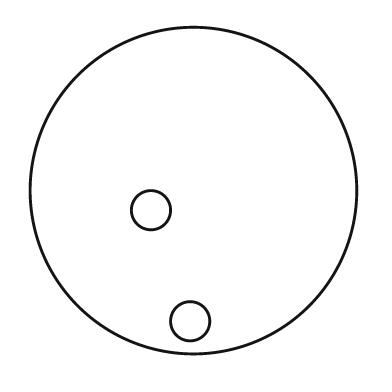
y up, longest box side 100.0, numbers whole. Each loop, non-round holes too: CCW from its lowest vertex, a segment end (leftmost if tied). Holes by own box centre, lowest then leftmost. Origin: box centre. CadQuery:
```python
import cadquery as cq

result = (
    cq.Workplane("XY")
    .moveTo(0.0, 0.0)
    .circle(50.0)
    .moveTo(-1.0, -40.0)
    .circle(6.0)
    .moveTo(-13.0, -6.0)
    .circle(6.0)
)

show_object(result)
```